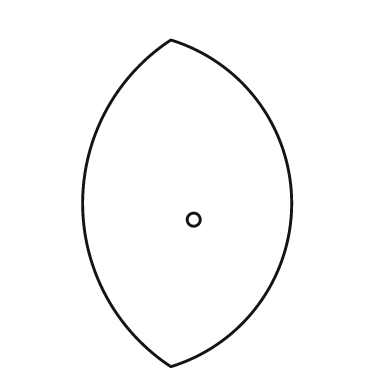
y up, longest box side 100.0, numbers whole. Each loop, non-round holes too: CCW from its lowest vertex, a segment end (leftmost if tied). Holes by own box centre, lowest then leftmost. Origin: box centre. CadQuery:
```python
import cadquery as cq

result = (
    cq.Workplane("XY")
    .moveTo(-5.0, -50.0)
    .threePointArc((32.0, 0.0), (-5.0, 50.0))
    .threePointArc((-32.0, 0.0), (-5.0, -50.0))
    .close()
    .moveTo(2.0, -5.0)
    .circle(2.0)
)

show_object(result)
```